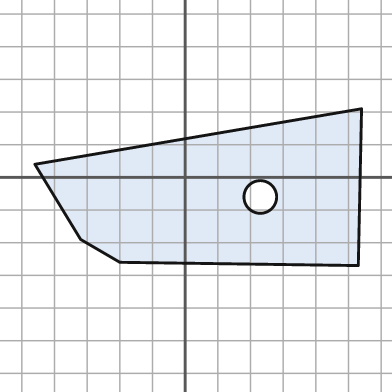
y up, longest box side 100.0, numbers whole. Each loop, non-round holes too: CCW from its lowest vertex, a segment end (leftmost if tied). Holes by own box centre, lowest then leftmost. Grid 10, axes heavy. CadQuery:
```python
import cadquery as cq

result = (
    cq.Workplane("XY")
    .moveTo(53.0, -27.0)
    .lineTo(54.0, 21.0)
    .lineTo(-46.0, 4.0)
    .lineTo(-32.0, -19.0)
    .lineTo(-20.0, -26.0)
    .close()
    .moveTo(23.0, -6.0)
    .circle(5.0)
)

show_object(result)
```